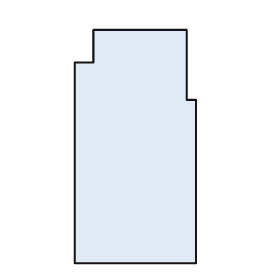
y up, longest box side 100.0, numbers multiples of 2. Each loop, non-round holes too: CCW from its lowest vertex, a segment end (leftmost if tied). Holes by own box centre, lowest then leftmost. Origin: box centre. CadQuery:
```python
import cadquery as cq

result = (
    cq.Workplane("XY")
    .moveTo(-26.0, -50.0)
    .lineTo(26.0, -50.0)
    .lineTo(26.0, 20.0)
    .lineTo(22.0, 20.0)
    .lineTo(22.0, 50.0)
    .lineTo(-18.0, 50.0)
    .lineTo(-18.0, 36.0)
    .lineTo(-26.0, 36.0)
    .close()
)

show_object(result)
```